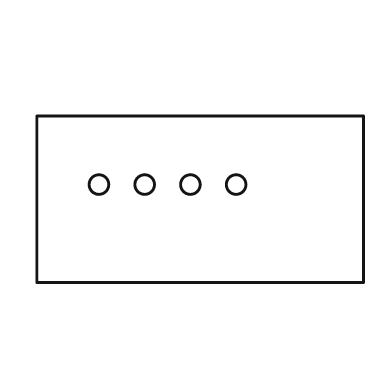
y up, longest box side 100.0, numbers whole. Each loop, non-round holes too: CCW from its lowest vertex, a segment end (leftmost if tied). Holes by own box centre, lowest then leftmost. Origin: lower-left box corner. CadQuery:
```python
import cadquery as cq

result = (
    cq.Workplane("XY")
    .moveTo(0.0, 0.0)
    .lineTo(100.0, 0.0)
    .lineTo(100.0, 51.0)
    .lineTo(0.0, 51.0)
    .close()
    .moveTo(19.0, 30.0)
    .circle(3.0)
    .moveTo(33.0, 30.0)
    .circle(3.0)
    .moveTo(47.0, 30.0)
    .circle(3.0)
    .moveTo(61.0, 30.0)
    .circle(3.0)
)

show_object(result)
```